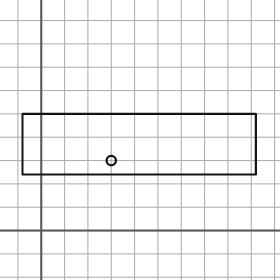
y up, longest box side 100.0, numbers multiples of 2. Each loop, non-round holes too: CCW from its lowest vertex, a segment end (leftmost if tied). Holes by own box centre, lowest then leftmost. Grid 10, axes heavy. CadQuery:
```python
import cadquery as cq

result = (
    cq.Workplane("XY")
    .moveTo(-8.0, 24.0)
    .lineTo(92.0, 24.0)
    .lineTo(92.0, 50.0)
    .lineTo(-8.0, 50.0)
    .close()
    .moveTo(30.0, 30.0)
    .circle(2.0)
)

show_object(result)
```